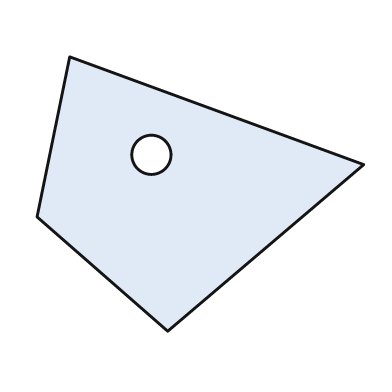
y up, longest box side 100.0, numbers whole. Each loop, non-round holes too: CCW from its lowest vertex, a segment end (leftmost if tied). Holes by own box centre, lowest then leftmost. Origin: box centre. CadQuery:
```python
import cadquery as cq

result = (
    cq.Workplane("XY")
    .moveTo(-10.0, -42.0)
    .lineTo(50.0, 9.0)
    .lineTo(-40.0, 42.0)
    .lineTo(-50.0, -7.0)
    .close()
    .moveTo(-15.0, 12.0)
    .circle(6.0)
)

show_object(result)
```